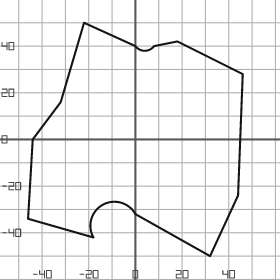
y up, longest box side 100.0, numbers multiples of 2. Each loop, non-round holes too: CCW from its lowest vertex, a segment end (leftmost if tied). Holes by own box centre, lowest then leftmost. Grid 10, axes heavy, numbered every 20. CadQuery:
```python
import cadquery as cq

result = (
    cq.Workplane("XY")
    .moveTo(32.0, -50.0)
    .lineTo(44.0, -24.0)
    .lineTo(46.0, 28.0)
    .lineTo(18.0, 42.0)
    .lineTo(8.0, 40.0)
    .threePointArc((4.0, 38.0), (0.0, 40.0))
    .lineTo(-22.0, 50.0)
    .lineTo(-32.0, 16.0)
    .lineTo(-44.0, 0.0)
    .lineTo(-46.0, -34.0)
    .lineTo(-18.0, -42.0)
    .threePointArc((-14.0, -28.0), (0.0, -32.0))
    .close()
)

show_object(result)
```